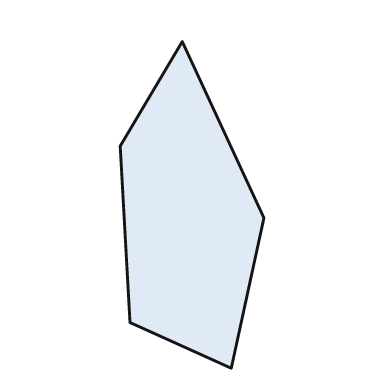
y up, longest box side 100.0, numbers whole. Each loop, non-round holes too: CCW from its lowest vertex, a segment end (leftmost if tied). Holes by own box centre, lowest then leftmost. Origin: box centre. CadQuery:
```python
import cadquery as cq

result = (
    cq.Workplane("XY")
    .moveTo(12.0, -50.0)
    .lineTo(22.0, -4.0)
    .lineTo(-3.0, 50.0)
    .lineTo(-22.0, 18.0)
    .lineTo(-19.0, -36.0)
    .close()
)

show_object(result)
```